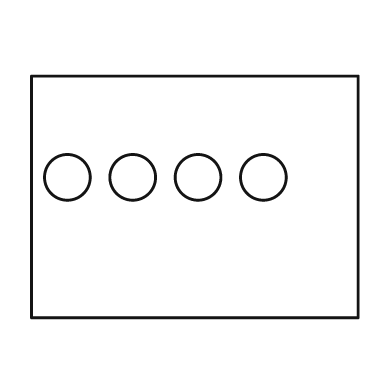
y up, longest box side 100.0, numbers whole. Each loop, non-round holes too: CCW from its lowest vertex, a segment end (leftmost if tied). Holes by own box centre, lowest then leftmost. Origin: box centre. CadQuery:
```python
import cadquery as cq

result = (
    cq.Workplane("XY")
    .moveTo(-50.0, -37.0)
    .lineTo(50.0, -37.0)
    .lineTo(50.0, 37.0)
    .lineTo(-50.0, 37.0)
    .close()
    .moveTo(-39.0, 6.0)
    .circle(7.0)
    .moveTo(-19.0, 6.0)
    .circle(7.0)
    .moveTo(1.0, 6.0)
    .circle(7.0)
    .moveTo(21.0, 6.0)
    .circle(7.0)
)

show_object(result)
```